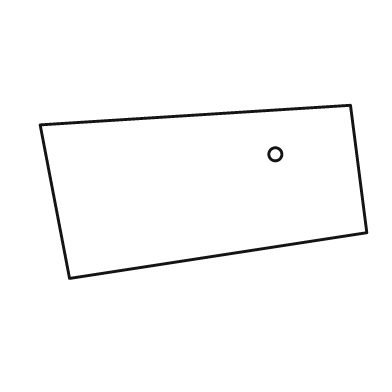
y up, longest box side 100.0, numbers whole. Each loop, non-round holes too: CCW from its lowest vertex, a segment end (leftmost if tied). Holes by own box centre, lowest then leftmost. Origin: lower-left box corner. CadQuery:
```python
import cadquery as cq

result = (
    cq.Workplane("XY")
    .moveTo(9.0, 0.0)
    .lineTo(100.0, 14.0)
    .lineTo(95.0, 53.0)
    .lineTo(0.0, 47.0)
    .close()
    .moveTo(72.0, 38.0)
    .circle(2.0)
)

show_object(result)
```